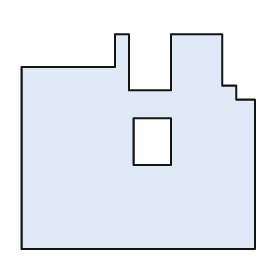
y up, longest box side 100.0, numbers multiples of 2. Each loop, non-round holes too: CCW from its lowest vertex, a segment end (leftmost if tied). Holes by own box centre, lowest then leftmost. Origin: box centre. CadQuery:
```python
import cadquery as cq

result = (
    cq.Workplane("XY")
    .moveTo(-50.0, -46.0)
    .lineTo(50.0, -46.0)
    .lineTo(50.0, 18.0)
    .lineTo(42.0, 18.0)
    .lineTo(42.0, 24.0)
    .lineTo(36.0, 24.0)
    .lineTo(36.0, 46.0)
    .lineTo(14.0, 46.0)
    .lineTo(14.0, 22.0)
    .lineTo(-4.0, 22.0)
    .lineTo(-4.0, 46.0)
    .lineTo(-10.0, 46.0)
    .lineTo(-10.0, 32.0)
    .lineTo(-50.0, 32.0)
    .close()
    .moveTo(-2.0, -10.0)
    .lineTo(14.0, -10.0)
    .lineTo(14.0, 10.0)
    .lineTo(-2.0, 10.0)
    .close()
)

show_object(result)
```